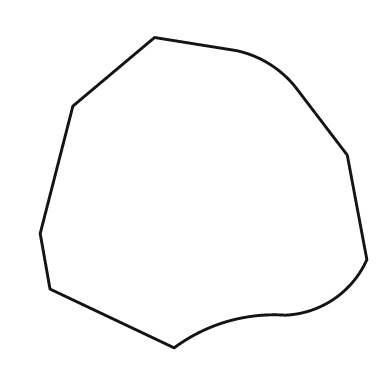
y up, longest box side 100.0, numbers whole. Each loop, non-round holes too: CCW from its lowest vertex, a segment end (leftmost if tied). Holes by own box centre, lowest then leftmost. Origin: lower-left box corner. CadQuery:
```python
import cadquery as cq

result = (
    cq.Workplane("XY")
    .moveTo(41.0, 0.0)
    .threePointArc((57.0, 8.0), (75.0, 10.0))
    .threePointArc((90.0, 15.0), (100.0, 27.0))
    .lineTo(94.0, 59.0)
    .lineTo(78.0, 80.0)
    .threePointArc((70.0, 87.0), (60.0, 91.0))
    .lineTo(35.0, 95.0)
    .lineTo(10.0, 74.0)
    .lineTo(0.0, 35.0)
    .lineTo(3.0, 18.0)
    .close()
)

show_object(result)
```